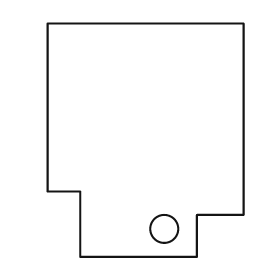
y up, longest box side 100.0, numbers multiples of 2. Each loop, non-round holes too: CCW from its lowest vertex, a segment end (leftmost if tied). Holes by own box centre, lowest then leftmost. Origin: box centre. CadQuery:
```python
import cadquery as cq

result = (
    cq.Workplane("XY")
    .moveTo(-28.0, -50.0)
    .lineTo(22.0, -50.0)
    .lineTo(22.0, -32.0)
    .lineTo(42.0, -32.0)
    .lineTo(42.0, 50.0)
    .lineTo(-42.0, 50.0)
    .lineTo(-42.0, -22.0)
    .lineTo(-28.0, -22.0)
    .close()
    .moveTo(8.0, -38.0)
    .circle(6.0)
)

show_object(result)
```